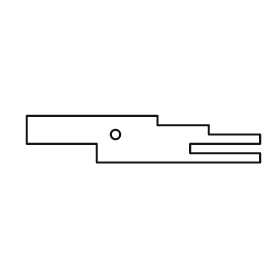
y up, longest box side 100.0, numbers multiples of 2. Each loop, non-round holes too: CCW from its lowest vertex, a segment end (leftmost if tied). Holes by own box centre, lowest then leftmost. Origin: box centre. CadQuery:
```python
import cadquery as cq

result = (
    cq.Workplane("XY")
    .moveTo(-20.0, -10.0)
    .lineTo(50.0, -10.0)
    .lineTo(50.0, -6.0)
    .lineTo(20.0, -6.0)
    .lineTo(20.0, -2.0)
    .lineTo(50.0, -2.0)
    .lineTo(50.0, 2.0)
    .lineTo(28.0, 2.0)
    .lineTo(28.0, 6.0)
    .lineTo(6.0, 6.0)
    .lineTo(6.0, 10.0)
    .lineTo(-50.0, 10.0)
    .lineTo(-50.0, -2.0)
    .lineTo(-20.0, -2.0)
    .close()
    .moveTo(-12.0, 2.0)
    .circle(2.0)
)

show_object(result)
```